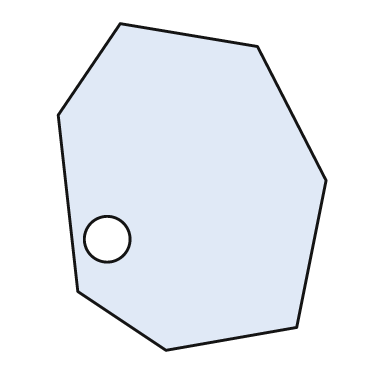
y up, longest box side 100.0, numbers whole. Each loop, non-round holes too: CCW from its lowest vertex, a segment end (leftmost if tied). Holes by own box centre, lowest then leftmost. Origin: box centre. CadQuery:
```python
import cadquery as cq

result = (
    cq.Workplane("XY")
    .moveTo(-8.0, -50.0)
    .lineTo(32.0, -43.0)
    .lineTo(41.0, 2.0)
    .lineTo(20.0, 43.0)
    .lineTo(-22.0, 50.0)
    .lineTo(-41.0, 22.0)
    .lineTo(-35.0, -32.0)
    .close()
    .moveTo(-26.0, -16.0)
    .circle(7.0)
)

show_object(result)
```